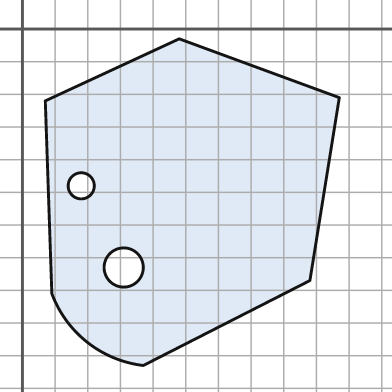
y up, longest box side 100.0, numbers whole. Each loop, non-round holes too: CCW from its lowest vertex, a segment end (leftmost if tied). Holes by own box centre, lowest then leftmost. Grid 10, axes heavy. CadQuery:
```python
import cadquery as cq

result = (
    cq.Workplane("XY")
    .moveTo(37.0, -103.0)
    .lineTo(88.0, -77.0)
    .lineTo(97.0, -21.0)
    .lineTo(48.0, -3.0)
    .lineTo(7.0, -22.0)
    .lineTo(9.0, -81.0)
    .threePointArc((20.0, -96.0), (37.0, -103.0))
    .close()
    .moveTo(31.0, -73.0)
    .circle(6.0)
    .moveTo(18.0, -48.0)
    .circle(4.0)
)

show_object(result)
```